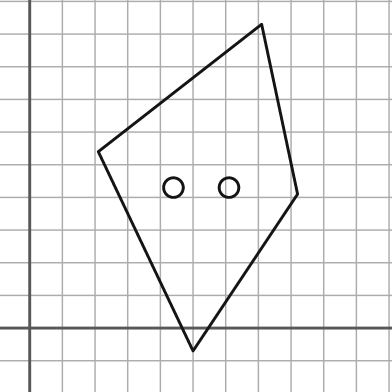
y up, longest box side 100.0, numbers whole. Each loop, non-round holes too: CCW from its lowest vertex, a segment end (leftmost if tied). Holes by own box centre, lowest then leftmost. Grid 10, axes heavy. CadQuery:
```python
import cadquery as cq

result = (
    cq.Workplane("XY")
    .moveTo(50.0, -7.0)
    .lineTo(82.0, 41.0)
    .lineTo(71.0, 93.0)
    .lineTo(21.0, 54.0)
    .close()
    .moveTo(44.0, 43.0)
    .circle(3.0)
    .moveTo(61.0, 43.0)
    .circle(3.0)
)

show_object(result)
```